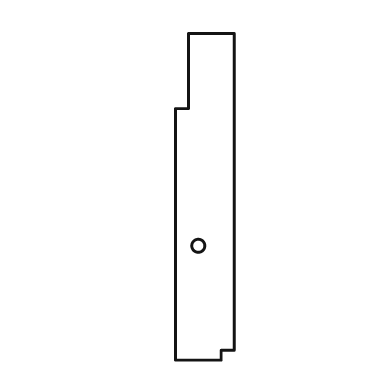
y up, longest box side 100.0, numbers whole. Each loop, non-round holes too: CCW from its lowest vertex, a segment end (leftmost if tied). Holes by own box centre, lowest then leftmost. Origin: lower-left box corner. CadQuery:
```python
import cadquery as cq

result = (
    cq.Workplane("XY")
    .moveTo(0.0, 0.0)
    .lineTo(14.0, 0.0)
    .lineTo(14.0, 3.0)
    .lineTo(18.0, 3.0)
    .lineTo(18.0, 100.0)
    .lineTo(4.0, 100.0)
    .lineTo(4.0, 77.0)
    .lineTo(0.0, 77.0)
    .close()
    .moveTo(7.0, 35.0)
    .circle(2.0)
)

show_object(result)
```